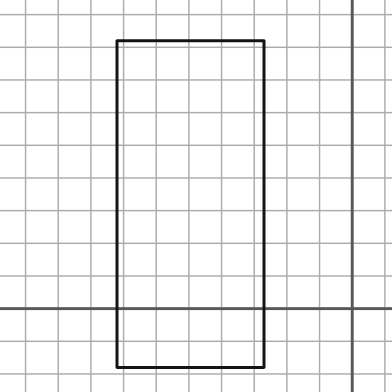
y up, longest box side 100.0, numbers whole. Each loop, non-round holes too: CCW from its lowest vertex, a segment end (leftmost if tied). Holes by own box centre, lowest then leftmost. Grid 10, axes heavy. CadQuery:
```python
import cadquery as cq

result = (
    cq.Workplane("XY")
    .moveTo(-72.0, -18.0)
    .lineTo(-27.0, -18.0)
    .lineTo(-27.0, 82.0)
    .lineTo(-72.0, 82.0)
    .close()
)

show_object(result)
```